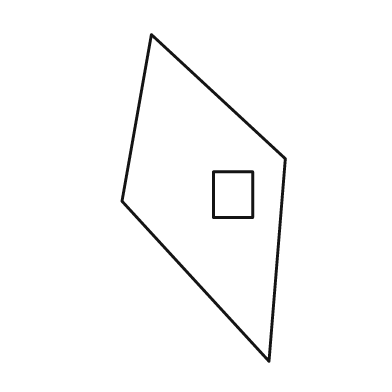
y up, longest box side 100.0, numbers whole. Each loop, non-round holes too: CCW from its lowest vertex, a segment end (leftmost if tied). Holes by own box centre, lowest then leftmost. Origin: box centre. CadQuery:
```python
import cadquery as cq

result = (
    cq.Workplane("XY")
    .moveTo(20.0, -50.0)
    .lineTo(25.0, 12.0)
    .lineTo(-16.0, 50.0)
    .lineTo(-25.0, -1.0)
    .close()
    .moveTo(3.0, -6.0)
    .lineTo(15.0, -6.0)
    .lineTo(15.0, 8.0)
    .lineTo(3.0, 8.0)
    .close()
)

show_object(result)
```